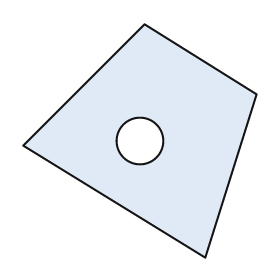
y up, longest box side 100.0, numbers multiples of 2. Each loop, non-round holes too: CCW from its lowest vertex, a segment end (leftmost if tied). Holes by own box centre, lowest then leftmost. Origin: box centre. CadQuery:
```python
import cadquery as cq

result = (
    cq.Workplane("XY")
    .moveTo(28.0, -50.0)
    .lineTo(50.0, 20.0)
    .lineTo(2.0, 50.0)
    .lineTo(-50.0, -2.0)
    .close()
    .moveTo(0.0, 0.0)
    .circle(10.0)
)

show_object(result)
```